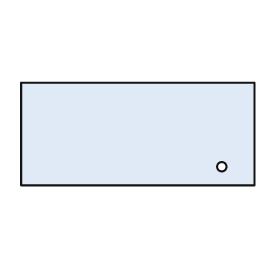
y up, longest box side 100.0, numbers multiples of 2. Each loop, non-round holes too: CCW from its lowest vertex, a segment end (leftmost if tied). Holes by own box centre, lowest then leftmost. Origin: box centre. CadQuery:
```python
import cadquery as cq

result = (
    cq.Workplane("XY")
    .moveTo(-50.0, -22.0)
    .lineTo(50.0, -22.0)
    .lineTo(50.0, 22.0)
    .lineTo(-50.0, 22.0)
    .close()
    .moveTo(36.0, -14.0)
    .circle(2.0)
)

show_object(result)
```